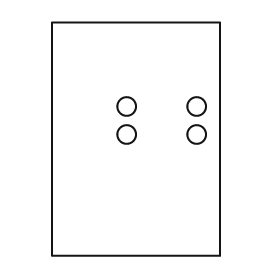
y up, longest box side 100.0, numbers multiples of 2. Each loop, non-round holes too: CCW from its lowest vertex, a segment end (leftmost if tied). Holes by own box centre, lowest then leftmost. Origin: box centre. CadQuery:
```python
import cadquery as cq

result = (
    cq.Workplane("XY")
    .moveTo(-36.0, -50.0)
    .lineTo(36.0, -50.0)
    .lineTo(36.0, 50.0)
    .lineTo(-36.0, 50.0)
    .close()
    .moveTo(-4.0, 2.0)
    .circle(4.0)
    .moveTo(26.0, 2.0)
    .circle(4.0)
    .moveTo(-4.0, 14.0)
    .circle(4.0)
    .moveTo(26.0, 14.0)
    .circle(4.0)
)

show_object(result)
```